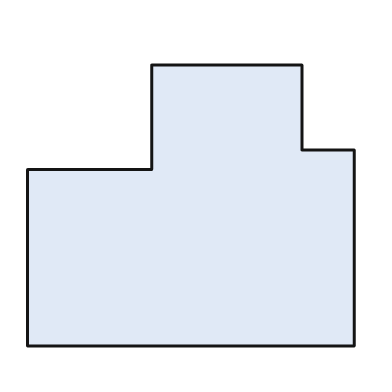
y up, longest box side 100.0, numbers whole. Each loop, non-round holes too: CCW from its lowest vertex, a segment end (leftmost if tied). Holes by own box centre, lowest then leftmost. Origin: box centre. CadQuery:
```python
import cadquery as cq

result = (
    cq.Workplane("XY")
    .moveTo(-50.0, -43.0)
    .lineTo(50.0, -43.0)
    .lineTo(50.0, 17.0)
    .lineTo(34.0, 17.0)
    .lineTo(34.0, 43.0)
    .lineTo(-12.0, 43.0)
    .lineTo(-12.0, 11.0)
    .lineTo(-50.0, 11.0)
    .close()
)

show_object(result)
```